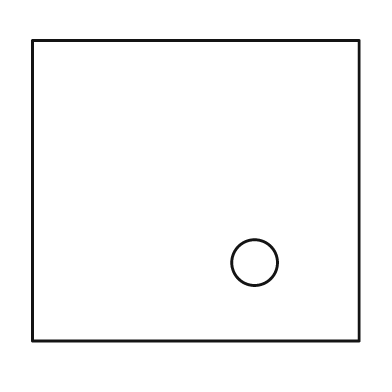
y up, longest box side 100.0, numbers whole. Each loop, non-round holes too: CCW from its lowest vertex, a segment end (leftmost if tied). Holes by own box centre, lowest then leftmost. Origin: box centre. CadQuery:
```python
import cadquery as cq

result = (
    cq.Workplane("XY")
    .moveTo(-50.0, -46.0)
    .lineTo(50.0, -46.0)
    .lineTo(50.0, 46.0)
    .lineTo(-50.0, 46.0)
    .close()
    .moveTo(18.0, -22.0)
    .circle(7.0)
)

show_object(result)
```